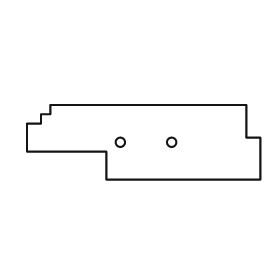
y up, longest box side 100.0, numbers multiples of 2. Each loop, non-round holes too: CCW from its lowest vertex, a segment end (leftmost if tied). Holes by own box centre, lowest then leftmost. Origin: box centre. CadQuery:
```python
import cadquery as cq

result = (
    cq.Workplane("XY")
    .moveTo(-16.0, -16.0)
    .lineTo(50.0, -16.0)
    .lineTo(50.0, 2.0)
    .lineTo(44.0, 2.0)
    .lineTo(44.0, 16.0)
    .lineTo(-40.0, 16.0)
    .lineTo(-40.0, 12.0)
    .lineTo(-44.0, 12.0)
    .lineTo(-44.0, 8.0)
    .lineTo(-50.0, 8.0)
    .lineTo(-50.0, -4.0)
    .lineTo(-16.0, -4.0)
    .close()
    .moveTo(-10.0, 0.0)
    .circle(2.0)
    .moveTo(12.0, 0.0)
    .circle(2.0)
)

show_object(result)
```